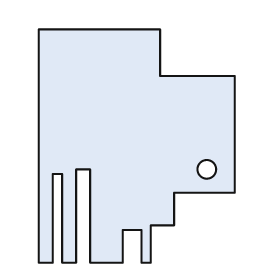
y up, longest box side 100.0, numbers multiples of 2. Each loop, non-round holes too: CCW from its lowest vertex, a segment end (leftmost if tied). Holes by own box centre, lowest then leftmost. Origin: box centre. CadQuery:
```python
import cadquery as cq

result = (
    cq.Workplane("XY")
    .moveTo(-42.0, -50.0)
    .lineTo(-36.0, -50.0)
    .lineTo(-36.0, -12.0)
    .lineTo(-32.0, -12.0)
    .lineTo(-32.0, -50.0)
    .lineTo(-26.0, -50.0)
    .lineTo(-26.0, -10.0)
    .lineTo(-20.0, -10.0)
    .lineTo(-20.0, -50.0)
    .lineTo(-6.0, -50.0)
    .lineTo(-6.0, -36.0)
    .lineTo(2.0, -36.0)
    .lineTo(2.0, -50.0)
    .lineTo(6.0, -50.0)
    .lineTo(6.0, -34.0)
    .lineTo(16.0, -34.0)
    .lineTo(16.0, -20.0)
    .lineTo(42.0, -20.0)
    .lineTo(42.0, 30.0)
    .lineTo(10.0, 30.0)
    .lineTo(10.0, 50.0)
    .lineTo(-42.0, 50.0)
    .close()
    .moveTo(30.0, -10.0)
    .circle(4.0)
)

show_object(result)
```